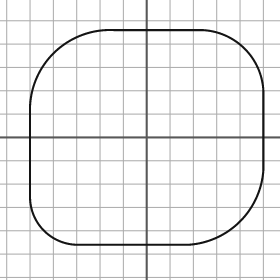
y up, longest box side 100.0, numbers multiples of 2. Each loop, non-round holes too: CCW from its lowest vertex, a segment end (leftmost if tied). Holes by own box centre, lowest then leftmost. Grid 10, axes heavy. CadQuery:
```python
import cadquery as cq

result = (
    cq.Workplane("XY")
    .moveTo(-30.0, -46.0)
    .lineTo(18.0, -46.0)
    .threePointArc((40.0, -36.0), (50.0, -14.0))
    .lineTo(50.0, 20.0)
    .threePointArc((42.0, 38.0), (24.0, 46.0))
    .lineTo(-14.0, 46.0)
    .threePointArc((-40.0, 36.0), (-50.0, 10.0))
    .lineTo(-50.0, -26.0)
    .threePointArc((-44.0, -40.0), (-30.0, -46.0))
    .close()
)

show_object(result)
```